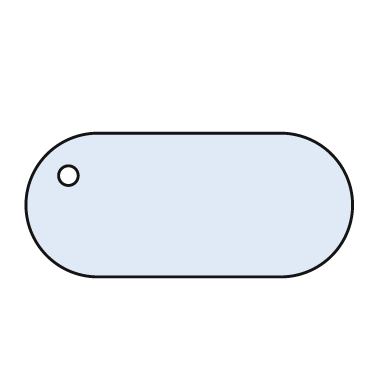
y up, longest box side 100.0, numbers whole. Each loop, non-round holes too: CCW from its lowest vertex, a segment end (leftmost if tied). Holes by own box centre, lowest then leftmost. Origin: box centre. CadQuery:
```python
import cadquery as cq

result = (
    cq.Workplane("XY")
    .moveTo(-28.0, -22.0)
    .lineTo(28.0, -22.0)
    .threePointArc((50.0, 0.0), (28.0, 22.0))
    .lineTo(-28.0, 22.0)
    .threePointArc((-50.0, 0.0), (-28.0, -22.0))
    .close()
    .moveTo(-37.0, 9.0)
    .circle(3.0)
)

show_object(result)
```